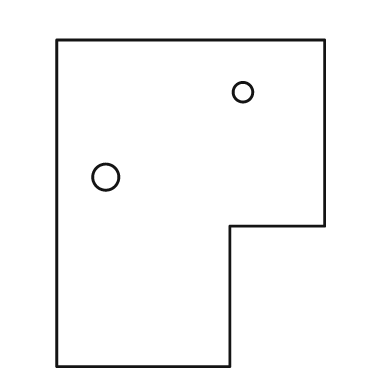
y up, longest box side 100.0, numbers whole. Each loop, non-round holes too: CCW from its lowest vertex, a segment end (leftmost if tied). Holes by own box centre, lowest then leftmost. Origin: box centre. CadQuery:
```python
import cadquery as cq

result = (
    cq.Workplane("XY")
    .moveTo(-41.0, -50.0)
    .lineTo(12.0, -50.0)
    .lineTo(12.0, -7.0)
    .lineTo(41.0, -7.0)
    .lineTo(41.0, 50.0)
    .lineTo(-41.0, 50.0)
    .close()
    .moveTo(-26.0, 8.0)
    .circle(4.0)
    .moveTo(16.0, 34.0)
    .circle(3.0)
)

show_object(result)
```